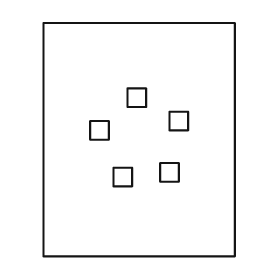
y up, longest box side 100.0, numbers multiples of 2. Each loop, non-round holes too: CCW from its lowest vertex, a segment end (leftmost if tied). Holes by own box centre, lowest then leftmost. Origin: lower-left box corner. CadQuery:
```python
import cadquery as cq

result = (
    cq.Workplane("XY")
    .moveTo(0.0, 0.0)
    .lineTo(82.0, 0.0)
    .lineTo(82.0, 100.0)
    .lineTo(0.0, 100.0)
    .close()
    .moveTo(30.0, 30.0)
    .lineTo(38.0, 30.0)
    .lineTo(38.0, 38.0)
    .lineTo(30.0, 38.0)
    .close()
    .moveTo(50.0, 32.0)
    .lineTo(58.0, 32.0)
    .lineTo(58.0, 40.0)
    .lineTo(50.0, 40.0)
    .close()
    .moveTo(20.0, 50.0)
    .lineTo(28.0, 50.0)
    .lineTo(28.0, 58.0)
    .lineTo(20.0, 58.0)
    .close()
    .moveTo(54.0, 54.0)
    .lineTo(62.0, 54.0)
    .lineTo(62.0, 62.0)
    .lineTo(54.0, 62.0)
    .close()
    .moveTo(36.0, 64.0)
    .lineTo(44.0, 64.0)
    .lineTo(44.0, 72.0)
    .lineTo(36.0, 72.0)
    .close()
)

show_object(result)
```